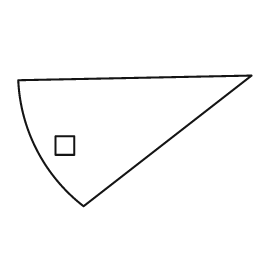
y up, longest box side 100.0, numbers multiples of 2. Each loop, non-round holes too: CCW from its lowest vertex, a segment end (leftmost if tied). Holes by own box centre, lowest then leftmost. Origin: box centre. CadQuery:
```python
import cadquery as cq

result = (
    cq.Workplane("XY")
    .moveTo(-22.0, -28.0)
    .lineTo(50.0, 28.0)
    .lineTo(-50.0, 26.0)
    .threePointArc((-42.0, -4.0), (-22.0, -28.0))
    .close()
    .moveTo(-34.0, -6.0)
    .lineTo(-26.0, -6.0)
    .lineTo(-26.0, 2.0)
    .lineTo(-34.0, 2.0)
    .close()
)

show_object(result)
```